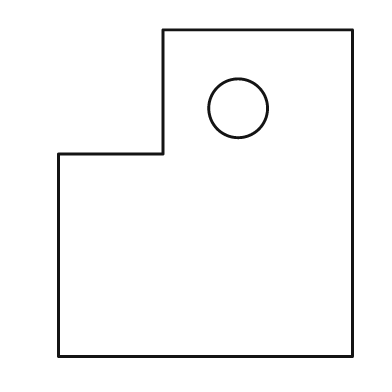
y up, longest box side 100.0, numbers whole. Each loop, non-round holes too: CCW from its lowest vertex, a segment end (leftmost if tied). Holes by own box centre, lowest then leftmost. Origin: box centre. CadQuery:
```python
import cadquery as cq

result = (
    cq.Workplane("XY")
    .moveTo(-45.0, -50.0)
    .lineTo(45.0, -50.0)
    .lineTo(45.0, 50.0)
    .lineTo(-13.0, 50.0)
    .lineTo(-13.0, 12.0)
    .lineTo(-45.0, 12.0)
    .close()
    .moveTo(10.0, 26.0)
    .circle(9.0)
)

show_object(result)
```